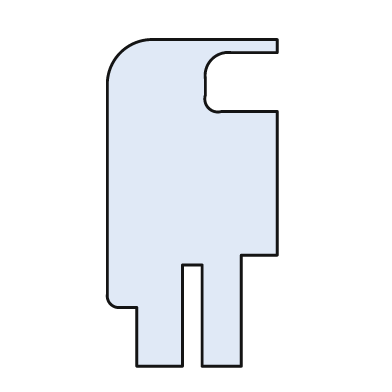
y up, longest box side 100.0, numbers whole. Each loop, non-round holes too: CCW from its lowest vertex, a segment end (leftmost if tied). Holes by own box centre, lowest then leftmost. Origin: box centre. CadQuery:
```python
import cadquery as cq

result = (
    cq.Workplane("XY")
    .moveTo(-17.0, -50.0)
    .lineTo(-3.0, -50.0)
    .lineTo(-3.0, -19.0)
    .lineTo(3.0, -19.0)
    .lineTo(3.0, -50.0)
    .lineTo(15.0, -50.0)
    .lineTo(15.0, -16.0)
    .lineTo(26.0, -16.0)
    .lineTo(26.0, 28.0)
    .lineTo(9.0, 28.0)
    .threePointArc((5.0, 29.0), (4.0, 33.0))
    .lineTo(4.0, 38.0)
    .threePointArc((6.0, 44.0), (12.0, 46.0))
    .lineTo(26.0, 46.0)
    .lineTo(26.0, 50.0)
    .lineTo(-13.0, 50.0)
    .threePointArc((-22.0, 46.0), (-26.0, 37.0))
    .lineTo(-26.0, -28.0)
    .threePointArc((-25.0, -31.0), (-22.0, -32.0))
    .lineTo(-17.0, -32.0)
    .close()
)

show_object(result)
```